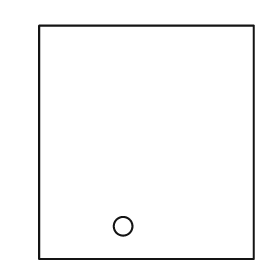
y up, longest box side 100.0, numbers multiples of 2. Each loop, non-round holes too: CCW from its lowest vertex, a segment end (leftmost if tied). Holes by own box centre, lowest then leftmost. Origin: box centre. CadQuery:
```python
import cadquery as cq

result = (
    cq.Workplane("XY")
    .moveTo(-46.0, -50.0)
    .lineTo(46.0, -50.0)
    .lineTo(46.0, 50.0)
    .lineTo(-46.0, 50.0)
    .close()
    .moveTo(-10.0, -36.0)
    .circle(4.0)
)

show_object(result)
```